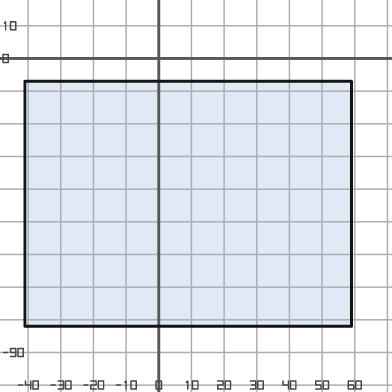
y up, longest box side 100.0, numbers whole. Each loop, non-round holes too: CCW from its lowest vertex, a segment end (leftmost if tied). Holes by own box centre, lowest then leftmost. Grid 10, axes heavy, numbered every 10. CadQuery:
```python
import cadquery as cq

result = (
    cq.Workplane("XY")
    .moveTo(-41.0, -82.0)
    .lineTo(59.0, -82.0)
    .lineTo(59.0, -7.0)
    .lineTo(-41.0, -7.0)
    .close()
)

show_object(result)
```